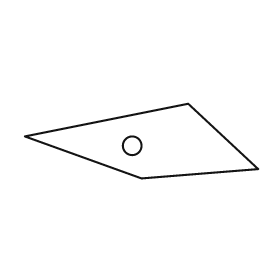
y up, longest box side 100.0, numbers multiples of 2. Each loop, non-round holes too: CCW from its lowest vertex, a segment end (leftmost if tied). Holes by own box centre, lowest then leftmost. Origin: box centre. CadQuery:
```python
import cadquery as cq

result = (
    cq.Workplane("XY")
    .moveTo(0.0, -16.0)
    .lineTo(50.0, -12.0)
    .lineTo(20.0, 16.0)
    .lineTo(-50.0, 2.0)
    .close()
    .moveTo(-4.0, -2.0)
    .circle(4.0)
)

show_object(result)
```